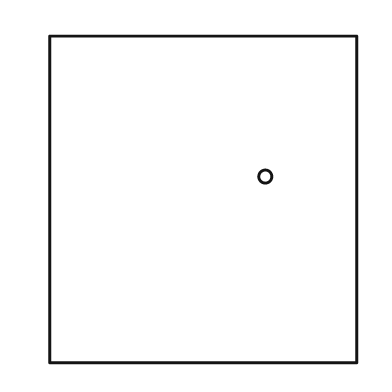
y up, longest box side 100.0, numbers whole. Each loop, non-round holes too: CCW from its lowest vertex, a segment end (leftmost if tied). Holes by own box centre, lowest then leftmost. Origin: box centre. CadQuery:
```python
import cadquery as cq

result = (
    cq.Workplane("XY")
    .moveTo(-47.0, -50.0)
    .lineTo(47.0, -50.0)
    .lineTo(47.0, 50.0)
    .lineTo(-47.0, 50.0)
    .close()
    .moveTo(19.0, 7.0)
    .circle(2.0)
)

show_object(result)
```